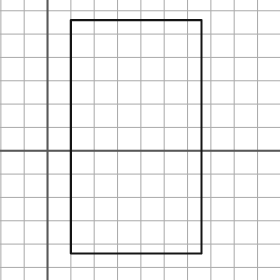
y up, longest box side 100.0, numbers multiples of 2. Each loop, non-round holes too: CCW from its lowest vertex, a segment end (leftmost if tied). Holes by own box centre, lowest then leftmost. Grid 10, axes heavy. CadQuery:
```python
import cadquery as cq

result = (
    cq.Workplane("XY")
    .moveTo(10.0, -44.0)
    .lineTo(66.0, -44.0)
    .lineTo(66.0, 56.0)
    .lineTo(10.0, 56.0)
    .close()
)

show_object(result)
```